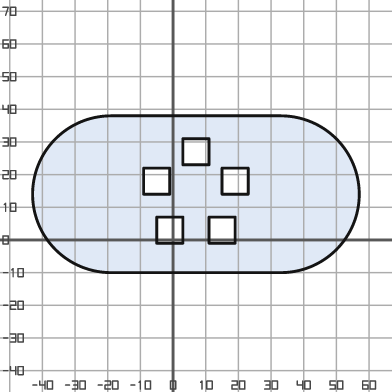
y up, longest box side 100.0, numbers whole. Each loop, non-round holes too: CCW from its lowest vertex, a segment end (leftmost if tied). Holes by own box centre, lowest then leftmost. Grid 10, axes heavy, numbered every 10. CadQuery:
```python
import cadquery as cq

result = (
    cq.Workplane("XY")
    .moveTo(-19.0, -10.0)
    .lineTo(33.0, -10.0)
    .threePointArc((57.0, 14.0), (33.0, 38.0))
    .lineTo(-19.0, 38.0)
    .threePointArc((-43.0, 14.0), (-19.0, -10.0))
    .close()
    .moveTo(-5.0, -1.0)
    .lineTo(3.0, -1.0)
    .lineTo(3.0, 7.0)
    .lineTo(-5.0, 7.0)
    .close()
    .moveTo(11.0, -1.0)
    .lineTo(19.0, -1.0)
    .lineTo(19.0, 7.0)
    .lineTo(11.0, 7.0)
    .close()
    .moveTo(-9.0, 14.0)
    .lineTo(-1.0, 14.0)
    .lineTo(-1.0, 22.0)
    .lineTo(-9.0, 22.0)
    .close()
    .moveTo(15.0, 14.0)
    .lineTo(23.0, 14.0)
    .lineTo(23.0, 22.0)
    .lineTo(15.0, 22.0)
    .close()
    .moveTo(3.0, 23.0)
    .lineTo(11.0, 23.0)
    .lineTo(11.0, 31.0)
    .lineTo(3.0, 31.0)
    .close()
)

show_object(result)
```